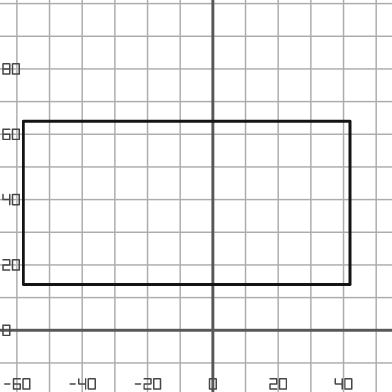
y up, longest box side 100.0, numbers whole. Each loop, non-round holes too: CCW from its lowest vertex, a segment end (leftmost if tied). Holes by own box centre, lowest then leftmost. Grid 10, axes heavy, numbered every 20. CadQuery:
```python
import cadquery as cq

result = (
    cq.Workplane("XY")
    .moveTo(-58.0, 14.0)
    .lineTo(42.0, 14.0)
    .lineTo(42.0, 64.0)
    .lineTo(-58.0, 64.0)
    .close()
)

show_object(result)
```